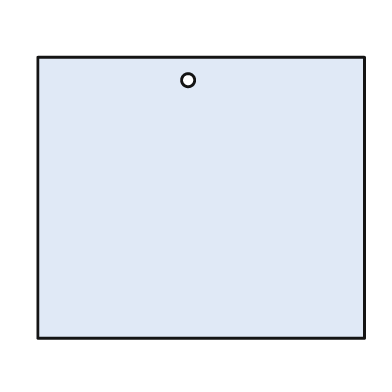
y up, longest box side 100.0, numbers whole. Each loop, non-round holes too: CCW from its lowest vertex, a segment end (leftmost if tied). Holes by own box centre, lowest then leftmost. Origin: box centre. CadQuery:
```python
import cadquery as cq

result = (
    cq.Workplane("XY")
    .moveTo(-50.0, -43.0)
    .lineTo(50.0, -43.0)
    .lineTo(50.0, 43.0)
    .lineTo(-50.0, 43.0)
    .close()
    .moveTo(-4.0, 36.0)
    .circle(2.0)
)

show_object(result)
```